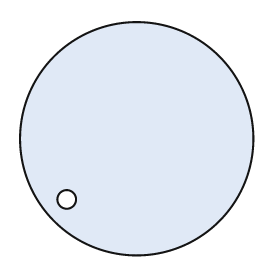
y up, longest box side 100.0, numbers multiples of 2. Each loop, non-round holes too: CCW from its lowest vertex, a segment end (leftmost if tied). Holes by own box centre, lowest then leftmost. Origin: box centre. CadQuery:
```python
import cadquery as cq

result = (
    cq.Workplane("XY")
    .moveTo(0.0, 0.0)
    .circle(50.0)
    .moveTo(-30.0, -26.0)
    .circle(4.0)
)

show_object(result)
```